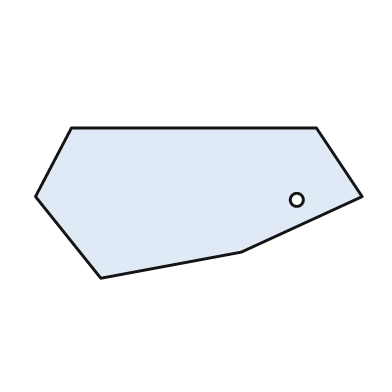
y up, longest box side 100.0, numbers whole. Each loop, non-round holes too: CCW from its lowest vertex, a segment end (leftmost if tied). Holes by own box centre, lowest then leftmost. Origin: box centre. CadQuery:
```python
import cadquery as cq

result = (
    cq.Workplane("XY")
    .moveTo(-30.0, -23.0)
    .lineTo(13.0, -15.0)
    .lineTo(50.0, 2.0)
    .lineTo(36.0, 23.0)
    .lineTo(-39.0, 23.0)
    .lineTo(-50.0, 2.0)
    .close()
    .moveTo(30.0, 1.0)
    .circle(2.0)
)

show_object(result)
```